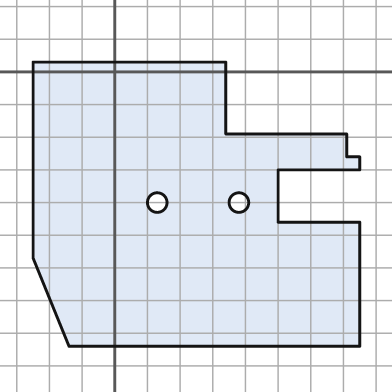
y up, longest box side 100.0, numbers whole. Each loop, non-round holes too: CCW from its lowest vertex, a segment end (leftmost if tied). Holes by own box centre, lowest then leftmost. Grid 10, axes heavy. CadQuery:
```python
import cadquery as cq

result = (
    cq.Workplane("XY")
    .moveTo(-14.0, -84.0)
    .lineTo(75.0, -84.0)
    .lineTo(75.0, -46.0)
    .lineTo(50.0, -46.0)
    .lineTo(50.0, -30.0)
    .lineTo(75.0, -30.0)
    .lineTo(75.0, -26.0)
    .lineTo(71.0, -26.0)
    .lineTo(71.0, -19.0)
    .lineTo(34.0, -19.0)
    .lineTo(34.0, 3.0)
    .lineTo(-25.0, 3.0)
    .lineTo(-25.0, -57.0)
    .close()
    .moveTo(13.0, -40.0)
    .circle(3.0)
    .moveTo(38.0, -40.0)
    .circle(3.0)
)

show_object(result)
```